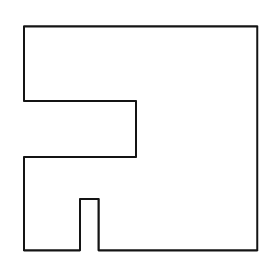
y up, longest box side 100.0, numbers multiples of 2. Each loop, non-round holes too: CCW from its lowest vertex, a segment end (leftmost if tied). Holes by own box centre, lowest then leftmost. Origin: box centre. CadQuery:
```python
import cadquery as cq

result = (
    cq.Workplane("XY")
    .moveTo(-50.0, -48.0)
    .lineTo(-26.0, -48.0)
    .lineTo(-26.0, -26.0)
    .lineTo(-18.0, -26.0)
    .lineTo(-18.0, -48.0)
    .lineTo(50.0, -48.0)
    .lineTo(50.0, 48.0)
    .lineTo(-50.0, 48.0)
    .lineTo(-50.0, 16.0)
    .lineTo(-2.0, 16.0)
    .lineTo(-2.0, -8.0)
    .lineTo(-50.0, -8.0)
    .close()
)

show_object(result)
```